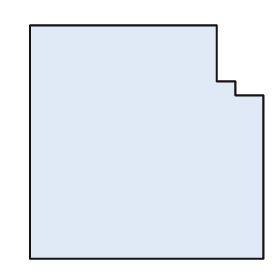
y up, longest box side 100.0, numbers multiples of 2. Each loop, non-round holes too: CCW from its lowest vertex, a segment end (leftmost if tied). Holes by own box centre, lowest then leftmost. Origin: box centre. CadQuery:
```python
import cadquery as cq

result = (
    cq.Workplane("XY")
    .moveTo(-50.0, -50.0)
    .lineTo(50.0, -50.0)
    .lineTo(50.0, 20.0)
    .lineTo(38.0, 20.0)
    .lineTo(38.0, 26.0)
    .lineTo(30.0, 26.0)
    .lineTo(30.0, 50.0)
    .lineTo(-50.0, 50.0)
    .close()
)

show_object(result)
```